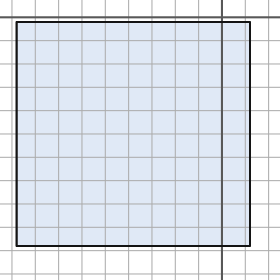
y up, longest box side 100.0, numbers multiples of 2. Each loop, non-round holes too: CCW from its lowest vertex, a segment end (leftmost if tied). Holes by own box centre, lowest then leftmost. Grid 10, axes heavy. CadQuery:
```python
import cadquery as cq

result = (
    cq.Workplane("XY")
    .moveTo(-88.0, -98.0)
    .lineTo(12.0, -98.0)
    .lineTo(12.0, -2.0)
    .lineTo(-88.0, -2.0)
    .close()
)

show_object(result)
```